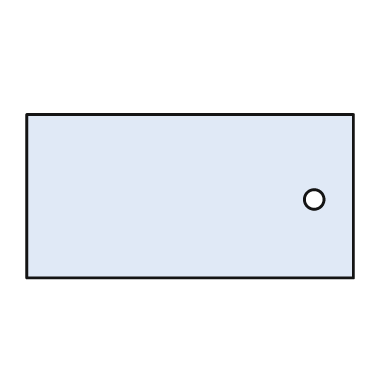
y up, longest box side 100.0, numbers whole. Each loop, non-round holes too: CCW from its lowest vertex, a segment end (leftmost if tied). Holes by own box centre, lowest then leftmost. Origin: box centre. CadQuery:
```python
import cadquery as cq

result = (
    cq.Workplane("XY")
    .moveTo(-50.0, -25.0)
    .lineTo(50.0, -25.0)
    .lineTo(50.0, 25.0)
    .lineTo(-50.0, 25.0)
    .close()
    .moveTo(38.0, -1.0)
    .circle(3.0)
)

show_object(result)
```